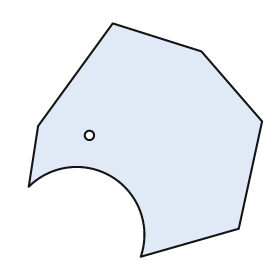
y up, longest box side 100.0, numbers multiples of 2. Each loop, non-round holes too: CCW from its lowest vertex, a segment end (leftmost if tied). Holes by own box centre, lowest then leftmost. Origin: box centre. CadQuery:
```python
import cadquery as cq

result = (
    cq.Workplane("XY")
    .moveTo(-2.0, -50.0)
    .lineTo(40.0, -38.0)
    .lineTo(50.0, 8.0)
    .lineTo(24.0, 38.0)
    .lineTo(-14.0, 50.0)
    .lineTo(-46.0, 6.0)
    .lineTo(-50.0, -20.0)
    .threePointArc((-14.0, -16.0), (-2.0, -50.0))
    .close()
    .moveTo(-24.0, 2.0)
    .circle(2.0)
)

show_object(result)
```